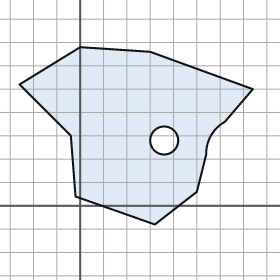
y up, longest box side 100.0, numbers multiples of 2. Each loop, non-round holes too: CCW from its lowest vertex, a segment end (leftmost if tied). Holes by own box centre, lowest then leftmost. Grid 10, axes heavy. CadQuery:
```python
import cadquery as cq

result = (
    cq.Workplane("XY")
    .moveTo(32.0, -8.0)
    .lineTo(50.0, 6.0)
    .lineTo(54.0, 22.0)
    .threePointArc((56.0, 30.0), (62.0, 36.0))
    .lineTo(74.0, 50.0)
    .lineTo(30.0, 66.0)
    .lineTo(0.0, 68.0)
    .lineTo(-26.0, 52.0)
    .lineTo(-4.0, 30.0)
    .lineTo(-2.0, 4.0)
    .close()
    .moveTo(36.0, 28.0)
    .circle(6.0)
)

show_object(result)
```